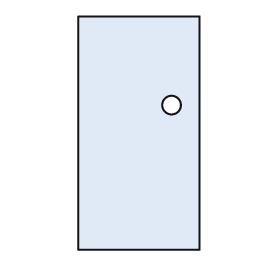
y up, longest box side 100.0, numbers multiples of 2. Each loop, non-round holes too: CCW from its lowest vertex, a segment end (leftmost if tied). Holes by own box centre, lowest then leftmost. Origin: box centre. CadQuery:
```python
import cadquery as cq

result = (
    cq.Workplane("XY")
    .moveTo(-26.0, -50.0)
    .lineTo(26.0, -50.0)
    .lineTo(26.0, 50.0)
    .lineTo(-26.0, 50.0)
    .close()
    .moveTo(14.0, 12.0)
    .circle(4.0)
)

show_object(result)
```